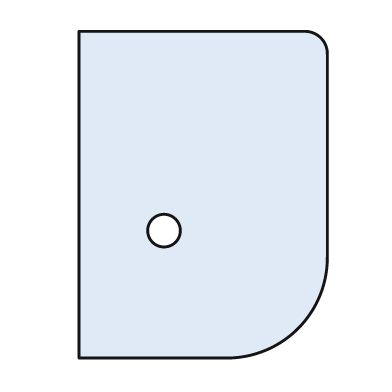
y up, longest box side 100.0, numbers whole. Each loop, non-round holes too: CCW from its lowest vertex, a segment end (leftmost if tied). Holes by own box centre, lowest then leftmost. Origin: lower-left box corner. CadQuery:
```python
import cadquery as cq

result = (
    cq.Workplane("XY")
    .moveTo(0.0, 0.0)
    .lineTo(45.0, 0.0)
    .threePointArc((67.0, 9.0), (76.0, 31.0))
    .lineTo(76.0, 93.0)
    .threePointArc((74.0, 98.0), (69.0, 100.0))
    .lineTo(0.0, 100.0)
    .close()
    .moveTo(26.0, 39.0)
    .circle(5.0)
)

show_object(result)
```